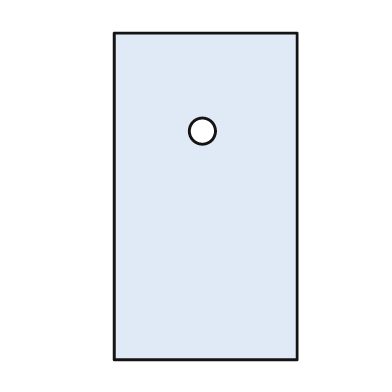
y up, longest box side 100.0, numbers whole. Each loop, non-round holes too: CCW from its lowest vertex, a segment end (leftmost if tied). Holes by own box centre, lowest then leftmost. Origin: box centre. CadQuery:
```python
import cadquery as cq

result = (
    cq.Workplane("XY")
    .moveTo(-28.0, -50.0)
    .lineTo(28.0, -50.0)
    .lineTo(28.0, 50.0)
    .lineTo(-28.0, 50.0)
    .close()
    .moveTo(-1.0, 20.0)
    .circle(4.0)
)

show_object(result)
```